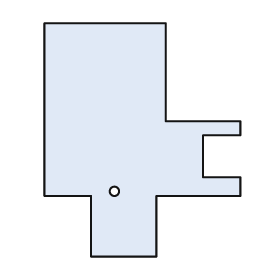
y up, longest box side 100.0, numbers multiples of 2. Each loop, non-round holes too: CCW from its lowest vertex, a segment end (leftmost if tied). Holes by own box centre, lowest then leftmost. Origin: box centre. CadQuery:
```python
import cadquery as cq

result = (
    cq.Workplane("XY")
    .moveTo(-22.0, -50.0)
    .lineTo(6.0, -50.0)
    .lineTo(6.0, -24.0)
    .lineTo(42.0, -24.0)
    .lineTo(42.0, -16.0)
    .lineTo(26.0, -16.0)
    .lineTo(26.0, 2.0)
    .lineTo(42.0, 2.0)
    .lineTo(42.0, 8.0)
    .lineTo(10.0, 8.0)
    .lineTo(10.0, 50.0)
    .lineTo(-42.0, 50.0)
    .lineTo(-42.0, -24.0)
    .lineTo(-22.0, -24.0)
    .close()
    .moveTo(-12.0, -22.0)
    .circle(2.0)
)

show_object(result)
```